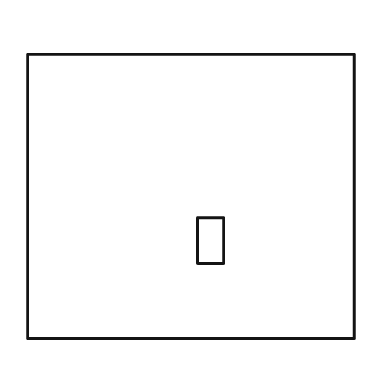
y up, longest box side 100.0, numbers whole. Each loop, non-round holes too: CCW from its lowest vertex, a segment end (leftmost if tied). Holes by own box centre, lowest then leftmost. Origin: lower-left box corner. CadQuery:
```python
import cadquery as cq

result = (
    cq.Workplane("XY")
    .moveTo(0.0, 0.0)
    .lineTo(100.0, 0.0)
    .lineTo(100.0, 87.0)
    .lineTo(0.0, 87.0)
    .close()
    .moveTo(52.0, 23.0)
    .lineTo(60.0, 23.0)
    .lineTo(60.0, 37.0)
    .lineTo(52.0, 37.0)
    .close()
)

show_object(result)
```